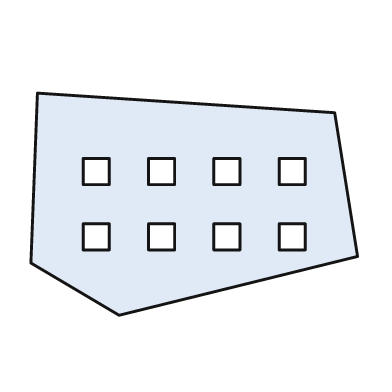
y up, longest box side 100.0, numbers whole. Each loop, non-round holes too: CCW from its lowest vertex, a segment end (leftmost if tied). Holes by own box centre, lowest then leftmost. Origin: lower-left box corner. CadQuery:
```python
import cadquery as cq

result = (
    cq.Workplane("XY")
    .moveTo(27.0, 0.0)
    .lineTo(100.0, 18.0)
    .lineTo(93.0, 62.0)
    .lineTo(2.0, 68.0)
    .lineTo(0.0, 16.0)
    .close()
    .moveTo(16.0, 20.0)
    .lineTo(24.0, 20.0)
    .lineTo(24.0, 28.0)
    .lineTo(16.0, 28.0)
    .close()
    .moveTo(36.0, 20.0)
    .lineTo(44.0, 20.0)
    .lineTo(44.0, 28.0)
    .lineTo(36.0, 28.0)
    .close()
    .moveTo(56.0, 20.0)
    .lineTo(64.0, 20.0)
    .lineTo(64.0, 28.0)
    .lineTo(56.0, 28.0)
    .close()
    .moveTo(76.0, 20.0)
    .lineTo(84.0, 20.0)
    .lineTo(84.0, 28.0)
    .lineTo(76.0, 28.0)
    .close()
    .moveTo(16.0, 40.0)
    .lineTo(24.0, 40.0)
    .lineTo(24.0, 48.0)
    .lineTo(16.0, 48.0)
    .close()
    .moveTo(36.0, 40.0)
    .lineTo(44.0, 40.0)
    .lineTo(44.0, 48.0)
    .lineTo(36.0, 48.0)
    .close()
    .moveTo(56.0, 40.0)
    .lineTo(64.0, 40.0)
    .lineTo(64.0, 48.0)
    .lineTo(56.0, 48.0)
    .close()
    .moveTo(76.0, 40.0)
    .lineTo(84.0, 40.0)
    .lineTo(84.0, 48.0)
    .lineTo(76.0, 48.0)
    .close()
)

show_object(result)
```